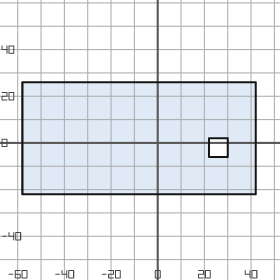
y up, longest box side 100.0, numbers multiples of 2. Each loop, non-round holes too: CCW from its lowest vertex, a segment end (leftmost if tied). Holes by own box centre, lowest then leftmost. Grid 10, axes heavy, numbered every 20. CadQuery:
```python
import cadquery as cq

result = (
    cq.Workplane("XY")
    .moveTo(-58.0, -22.0)
    .lineTo(42.0, -22.0)
    .lineTo(42.0, 26.0)
    .lineTo(-58.0, 26.0)
    .close()
    .moveTo(22.0, -6.0)
    .lineTo(30.0, -6.0)
    .lineTo(30.0, 2.0)
    .lineTo(22.0, 2.0)
    .close()
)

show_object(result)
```